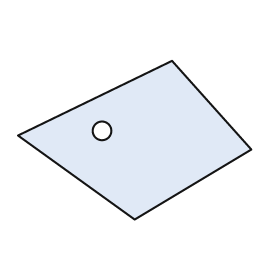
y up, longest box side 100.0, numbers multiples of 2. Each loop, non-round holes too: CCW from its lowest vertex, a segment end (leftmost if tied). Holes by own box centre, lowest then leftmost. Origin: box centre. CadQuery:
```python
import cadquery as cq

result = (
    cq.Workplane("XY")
    .moveTo(0.0, -34.0)
    .lineTo(50.0, -4.0)
    .lineTo(16.0, 34.0)
    .lineTo(-50.0, 2.0)
    .close()
    .moveTo(-14.0, 4.0)
    .circle(4.0)
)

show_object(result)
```